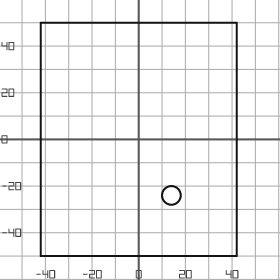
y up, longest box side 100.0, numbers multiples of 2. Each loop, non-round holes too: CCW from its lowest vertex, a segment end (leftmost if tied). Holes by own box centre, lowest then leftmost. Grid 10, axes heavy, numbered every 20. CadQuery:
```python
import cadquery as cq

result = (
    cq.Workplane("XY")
    .moveTo(-42.0, -50.0)
    .lineTo(42.0, -50.0)
    .lineTo(42.0, 50.0)
    .lineTo(-42.0, 50.0)
    .close()
    .moveTo(14.0, -24.0)
    .circle(4.0)
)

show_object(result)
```